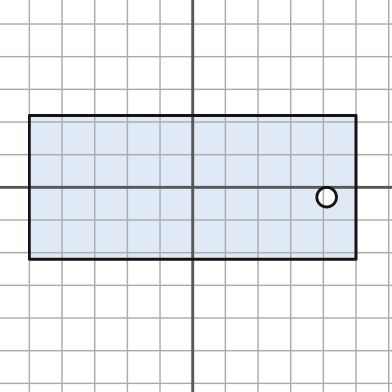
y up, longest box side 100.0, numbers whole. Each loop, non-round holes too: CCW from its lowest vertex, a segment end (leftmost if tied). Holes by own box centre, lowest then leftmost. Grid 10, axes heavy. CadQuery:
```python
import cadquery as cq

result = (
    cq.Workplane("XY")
    .moveTo(-50.0, -22.0)
    .lineTo(50.0, -22.0)
    .lineTo(50.0, 22.0)
    .lineTo(-50.0, 22.0)
    .close()
    .moveTo(41.0, -3.0)
    .circle(3.0)
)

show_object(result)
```